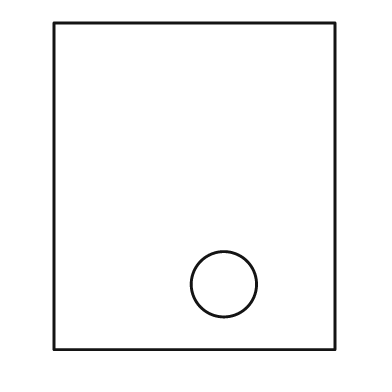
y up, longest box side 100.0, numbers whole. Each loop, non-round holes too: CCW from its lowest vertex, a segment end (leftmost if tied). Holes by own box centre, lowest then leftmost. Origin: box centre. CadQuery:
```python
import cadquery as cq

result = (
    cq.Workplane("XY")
    .moveTo(-43.0, -50.0)
    .lineTo(43.0, -50.0)
    .lineTo(43.0, 50.0)
    .lineTo(-43.0, 50.0)
    .close()
    .moveTo(9.0, -30.0)
    .circle(10.0)
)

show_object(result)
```